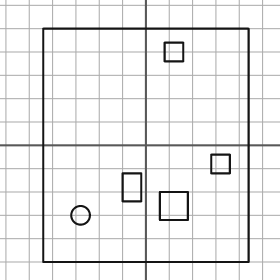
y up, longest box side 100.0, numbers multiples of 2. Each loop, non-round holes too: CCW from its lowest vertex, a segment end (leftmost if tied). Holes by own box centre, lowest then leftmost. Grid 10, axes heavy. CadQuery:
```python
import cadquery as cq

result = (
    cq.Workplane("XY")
    .moveTo(-44.0, -50.0)
    .lineTo(44.0, -50.0)
    .lineTo(44.0, 50.0)
    .lineTo(-44.0, 50.0)
    .close()
    .moveTo(-28.0, -30.0)
    .circle(4.0)
    .moveTo(6.0, -32.0)
    .lineTo(18.0, -32.0)
    .lineTo(18.0, -20.0)
    .lineTo(6.0, -20.0)
    .close()
    .moveTo(-10.0, -24.0)
    .lineTo(-2.0, -24.0)
    .lineTo(-2.0, -12.0)
    .lineTo(-10.0, -12.0)
    .close()
    .moveTo(28.0, -12.0)
    .lineTo(36.0, -12.0)
    .lineTo(36.0, -4.0)
    .lineTo(28.0, -4.0)
    .close()
    .moveTo(8.0, 36.0)
    .lineTo(16.0, 36.0)
    .lineTo(16.0, 44.0)
    .lineTo(8.0, 44.0)
    .close()
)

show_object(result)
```